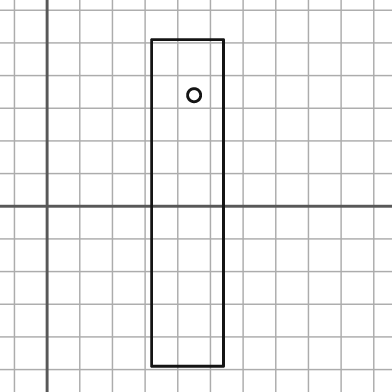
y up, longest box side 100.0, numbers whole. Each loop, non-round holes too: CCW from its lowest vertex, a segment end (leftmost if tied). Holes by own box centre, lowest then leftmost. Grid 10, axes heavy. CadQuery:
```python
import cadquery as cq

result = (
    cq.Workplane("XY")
    .moveTo(32.0, -49.0)
    .lineTo(54.0, -49.0)
    .lineTo(54.0, 51.0)
    .lineTo(32.0, 51.0)
    .close()
    .moveTo(45.0, 34.0)
    .circle(2.0)
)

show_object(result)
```